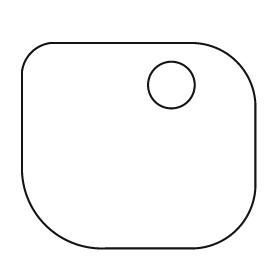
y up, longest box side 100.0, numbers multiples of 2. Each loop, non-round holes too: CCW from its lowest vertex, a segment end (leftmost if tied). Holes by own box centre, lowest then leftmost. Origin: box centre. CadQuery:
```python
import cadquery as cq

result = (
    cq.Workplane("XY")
    .moveTo(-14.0, -44.0)
    .lineTo(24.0, -44.0)
    .threePointArc((42.0, -36.0), (50.0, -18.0))
    .lineTo(50.0, 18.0)
    .threePointArc((42.0, 36.0), (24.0, 44.0))
    .lineTo(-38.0, 44.0)
    .threePointArc((-46.0, 40.0), (-50.0, 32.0))
    .lineTo(-50.0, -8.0)
    .threePointArc((-40.0, -34.0), (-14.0, -44.0))
    .close()
    .moveTo(14.0, 26.0)
    .circle(10.0)
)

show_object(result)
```